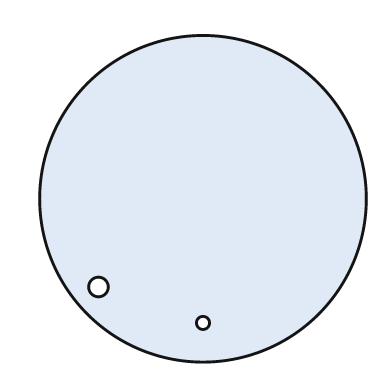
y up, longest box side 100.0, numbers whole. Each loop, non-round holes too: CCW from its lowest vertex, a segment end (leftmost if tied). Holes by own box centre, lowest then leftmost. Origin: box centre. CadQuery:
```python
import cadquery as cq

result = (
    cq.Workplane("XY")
    .moveTo(0.0, 0.0)
    .circle(50.0)
    .moveTo(0.0, -38.0)
    .circle(2.0)
    .moveTo(-32.0, -27.0)
    .circle(3.0)
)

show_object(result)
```